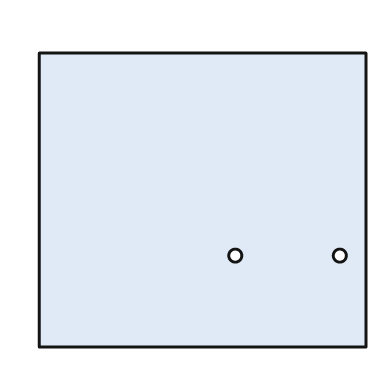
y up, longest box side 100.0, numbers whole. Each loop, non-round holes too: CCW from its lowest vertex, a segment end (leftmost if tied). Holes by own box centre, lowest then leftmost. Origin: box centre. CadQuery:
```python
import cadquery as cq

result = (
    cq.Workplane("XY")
    .moveTo(-50.0, -45.0)
    .lineTo(50.0, -45.0)
    .lineTo(50.0, 45.0)
    .lineTo(-50.0, 45.0)
    .close()
    .moveTo(10.0, -17.0)
    .circle(2.0)
    .moveTo(42.0, -17.0)
    .circle(2.0)
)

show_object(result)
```